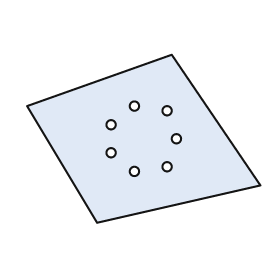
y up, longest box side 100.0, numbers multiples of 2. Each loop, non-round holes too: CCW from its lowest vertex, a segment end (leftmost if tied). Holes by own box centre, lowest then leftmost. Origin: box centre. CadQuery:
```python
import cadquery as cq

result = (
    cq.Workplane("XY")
    .moveTo(-20.0, -36.0)
    .lineTo(50.0, -20.0)
    .lineTo(12.0, 36.0)
    .lineTo(-50.0, 14.0)
    .close()
    .moveTo(-4.0, -14.0)
    .circle(2.0)
    .moveTo(10.0, -12.0)
    .circle(2.0)
    .moveTo(-14.0, -6.0)
    .circle(2.0)
    .moveTo(14.0, 0.0)
    .circle(2.0)
    .moveTo(-14.0, 6.0)
    .circle(2.0)
    .moveTo(10.0, 12.0)
    .circle(2.0)
    .moveTo(-4.0, 14.0)
    .circle(2.0)
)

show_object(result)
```